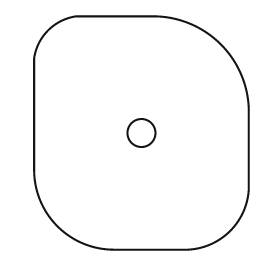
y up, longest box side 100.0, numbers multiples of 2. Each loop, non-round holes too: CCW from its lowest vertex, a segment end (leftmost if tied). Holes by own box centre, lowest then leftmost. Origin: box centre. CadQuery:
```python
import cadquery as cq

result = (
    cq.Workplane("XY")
    .moveTo(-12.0, -50.0)
    .lineTo(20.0, -50.0)
    .threePointArc((38.0, -42.0), (46.0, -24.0))
    .lineTo(46.0, 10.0)
    .threePointArc((34.0, 38.0), (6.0, 50.0))
    .lineTo(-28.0, 50.0)
    .threePointArc((-40.0, 44.0), (-46.0, 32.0))
    .lineTo(-46.0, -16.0)
    .threePointArc((-36.0, -40.0), (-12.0, -50.0))
    .close()
    .moveTo(0.0, 0.0)
    .circle(6.0)
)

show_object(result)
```